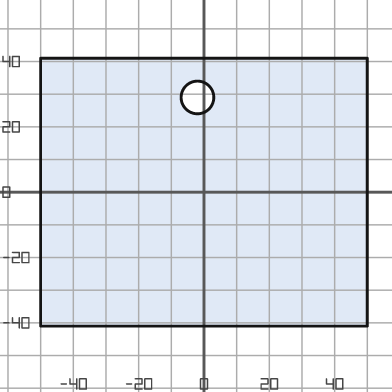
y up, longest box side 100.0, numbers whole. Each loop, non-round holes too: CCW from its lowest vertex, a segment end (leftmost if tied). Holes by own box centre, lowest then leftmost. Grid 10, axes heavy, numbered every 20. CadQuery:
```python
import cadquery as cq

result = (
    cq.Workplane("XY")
    .moveTo(-50.0, -41.0)
    .lineTo(50.0, -41.0)
    .lineTo(50.0, 41.0)
    .lineTo(-50.0, 41.0)
    .close()
    .moveTo(-2.0, 29.0)
    .circle(5.0)
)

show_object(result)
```